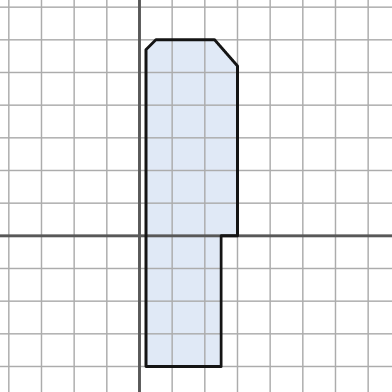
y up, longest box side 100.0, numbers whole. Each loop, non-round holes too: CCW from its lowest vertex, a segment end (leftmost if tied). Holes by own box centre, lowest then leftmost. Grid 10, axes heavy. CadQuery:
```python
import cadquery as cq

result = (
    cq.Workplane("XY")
    .moveTo(2.0, -40.0)
    .lineTo(25.0, -40.0)
    .lineTo(25.0, 0.0)
    .lineTo(30.0, 0.0)
    .lineTo(30.0, 52.0)
    .lineTo(23.0, 60.0)
    .lineTo(5.0, 60.0)
    .lineTo(2.0, 57.0)
    .close()
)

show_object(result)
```